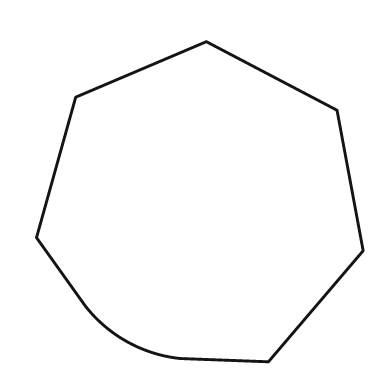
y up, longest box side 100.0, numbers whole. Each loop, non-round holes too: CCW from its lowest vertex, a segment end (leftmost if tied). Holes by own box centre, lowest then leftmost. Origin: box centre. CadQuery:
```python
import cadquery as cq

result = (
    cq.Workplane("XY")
    .moveTo(21.0, -49.0)
    .lineTo(50.0, -15.0)
    .lineTo(42.0, 28.0)
    .lineTo(2.0, 49.0)
    .lineTo(-38.0, 32.0)
    .lineTo(-50.0, -11.0)
    .lineTo(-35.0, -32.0)
    .threePointArc((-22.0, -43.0), (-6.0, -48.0))
    .close()
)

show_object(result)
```